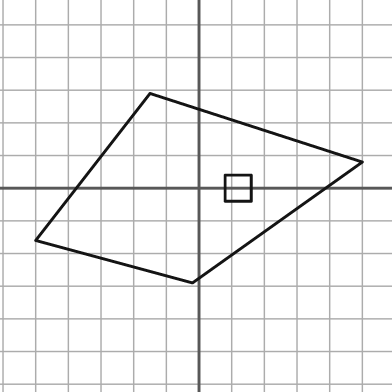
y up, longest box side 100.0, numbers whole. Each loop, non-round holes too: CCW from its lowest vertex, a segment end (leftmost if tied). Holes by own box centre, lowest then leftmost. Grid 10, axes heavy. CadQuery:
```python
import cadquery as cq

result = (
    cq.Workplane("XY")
    .moveTo(-2.0, -29.0)
    .lineTo(50.0, 8.0)
    .lineTo(-15.0, 29.0)
    .lineTo(-50.0, -16.0)
    .close()
    .moveTo(8.0, -4.0)
    .lineTo(16.0, -4.0)
    .lineTo(16.0, 4.0)
    .lineTo(8.0, 4.0)
    .close()
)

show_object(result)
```